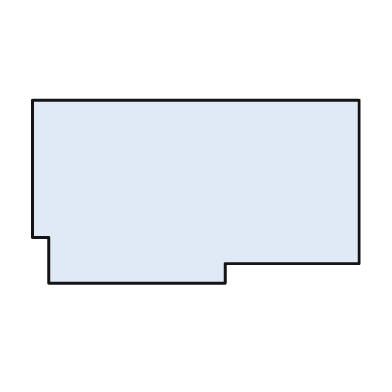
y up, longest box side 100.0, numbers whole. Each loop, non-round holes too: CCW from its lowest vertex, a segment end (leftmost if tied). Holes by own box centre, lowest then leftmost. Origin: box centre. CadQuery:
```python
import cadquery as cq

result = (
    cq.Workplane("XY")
    .moveTo(-45.0, -28.0)
    .lineTo(9.0, -28.0)
    .lineTo(9.0, -22.0)
    .lineTo(50.0, -22.0)
    .lineTo(50.0, 28.0)
    .lineTo(-50.0, 28.0)
    .lineTo(-50.0, -14.0)
    .lineTo(-45.0, -14.0)
    .close()
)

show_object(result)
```